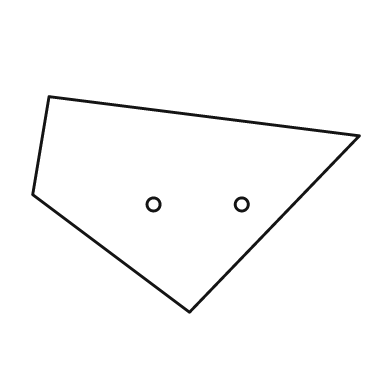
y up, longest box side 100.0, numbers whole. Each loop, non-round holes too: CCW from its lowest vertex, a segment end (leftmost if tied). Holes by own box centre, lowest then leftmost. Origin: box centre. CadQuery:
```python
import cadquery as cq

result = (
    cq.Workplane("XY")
    .moveTo(-2.0, -33.0)
    .lineTo(50.0, 21.0)
    .lineTo(-45.0, 33.0)
    .lineTo(-50.0, 3.0)
    .close()
    .moveTo(-13.0, 0.0)
    .circle(2.0)
    .moveTo(14.0, 0.0)
    .circle(2.0)
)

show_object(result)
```